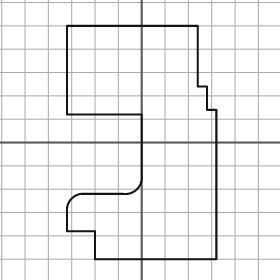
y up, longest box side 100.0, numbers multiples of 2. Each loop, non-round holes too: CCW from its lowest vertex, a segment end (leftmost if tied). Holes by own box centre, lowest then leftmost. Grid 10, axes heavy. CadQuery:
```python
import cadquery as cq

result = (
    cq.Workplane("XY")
    .moveTo(-20.0, -50.0)
    .lineTo(32.0, -50.0)
    .lineTo(32.0, 14.0)
    .lineTo(28.0, 14.0)
    .lineTo(28.0, 24.0)
    .lineTo(24.0, 24.0)
    .lineTo(24.0, 50.0)
    .lineTo(-32.0, 50.0)
    .lineTo(-32.0, 12.0)
    .lineTo(0.0, 12.0)
    .lineTo(0.0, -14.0)
    .threePointArc((-2.0, -20.0), (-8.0, -22.0))
    .lineTo(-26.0, -22.0)
    .threePointArc((-30.0, -24.0), (-32.0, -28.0))
    .lineTo(-32.0, -38.0)
    .lineTo(-20.0, -38.0)
    .close()
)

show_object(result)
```